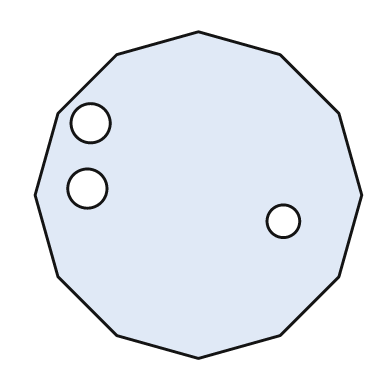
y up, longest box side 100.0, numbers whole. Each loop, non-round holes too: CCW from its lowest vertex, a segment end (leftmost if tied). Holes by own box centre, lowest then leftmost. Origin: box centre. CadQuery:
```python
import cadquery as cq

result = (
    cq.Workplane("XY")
    .moveTo(0.0, -50.0)
    .lineTo(25.0, -43.0)
    .lineTo(43.0, -25.0)
    .lineTo(50.0, 0.0)
    .lineTo(43.0, 25.0)
    .lineTo(25.0, 43.0)
    .lineTo(0.0, 50.0)
    .lineTo(-25.0, 43.0)
    .lineTo(-43.0, 25.0)
    .lineTo(-50.0, 0.0)
    .lineTo(-43.0, -25.0)
    .lineTo(-25.0, -43.0)
    .close()
    .moveTo(26.0, -8.0)
    .circle(5.0)
    .moveTo(-34.0, 2.0)
    .circle(6.0)
    .moveTo(-33.0, 22.0)
    .circle(6.0)
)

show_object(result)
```